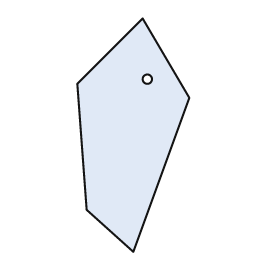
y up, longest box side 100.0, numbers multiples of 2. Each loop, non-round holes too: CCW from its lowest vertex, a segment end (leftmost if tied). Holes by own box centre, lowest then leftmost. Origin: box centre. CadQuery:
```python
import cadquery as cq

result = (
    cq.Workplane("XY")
    .moveTo(0.0, -50.0)
    .lineTo(24.0, 16.0)
    .lineTo(4.0, 50.0)
    .lineTo(-24.0, 22.0)
    .lineTo(-20.0, -32.0)
    .close()
    .moveTo(6.0, 24.0)
    .circle(2.0)
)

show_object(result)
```